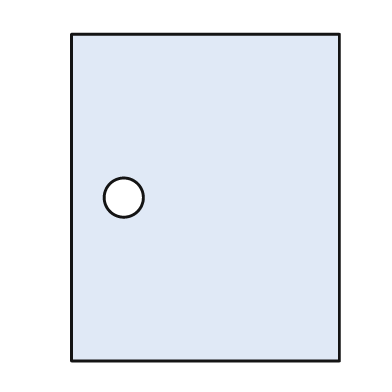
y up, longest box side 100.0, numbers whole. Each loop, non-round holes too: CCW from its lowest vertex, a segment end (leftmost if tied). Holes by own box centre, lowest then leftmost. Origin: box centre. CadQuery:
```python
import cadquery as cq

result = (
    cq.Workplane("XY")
    .moveTo(-41.0, -50.0)
    .lineTo(41.0, -50.0)
    .lineTo(41.0, 50.0)
    .lineTo(-41.0, 50.0)
    .close()
    .moveTo(-25.0, 0.0)
    .circle(6.0)
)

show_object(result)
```